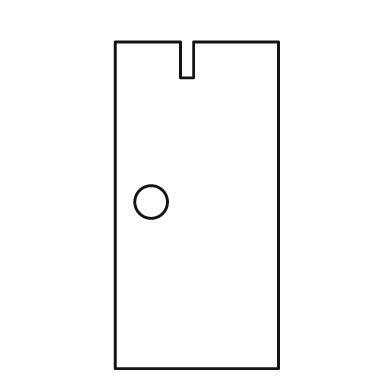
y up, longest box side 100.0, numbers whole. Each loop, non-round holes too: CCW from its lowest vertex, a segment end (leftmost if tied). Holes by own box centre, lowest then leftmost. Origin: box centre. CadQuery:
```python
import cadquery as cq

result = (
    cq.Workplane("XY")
    .moveTo(-25.0, -50.0)
    .lineTo(25.0, -50.0)
    .lineTo(25.0, 50.0)
    .lineTo(-1.0, 50.0)
    .lineTo(-1.0, 39.0)
    .lineTo(-5.0, 39.0)
    .lineTo(-5.0, 50.0)
    .lineTo(-25.0, 50.0)
    .close()
    .moveTo(-14.0, 1.0)
    .circle(5.0)
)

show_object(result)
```